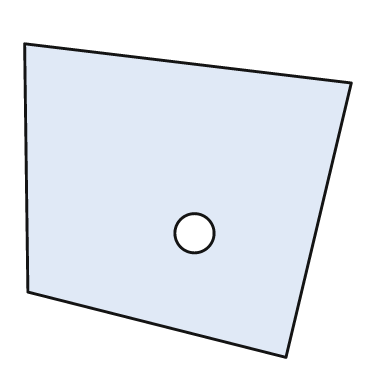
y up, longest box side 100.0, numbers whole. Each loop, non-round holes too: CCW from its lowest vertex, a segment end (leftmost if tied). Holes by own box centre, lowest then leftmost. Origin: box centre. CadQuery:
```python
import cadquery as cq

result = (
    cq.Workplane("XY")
    .moveTo(30.0, -48.0)
    .lineTo(50.0, 36.0)
    .lineTo(-50.0, 48.0)
    .lineTo(-49.0, -28.0)
    .close()
    .moveTo(2.0, -10.0)
    .circle(6.0)
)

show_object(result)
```